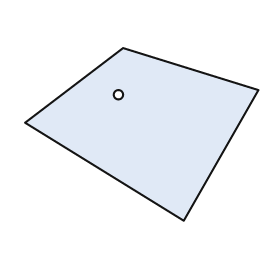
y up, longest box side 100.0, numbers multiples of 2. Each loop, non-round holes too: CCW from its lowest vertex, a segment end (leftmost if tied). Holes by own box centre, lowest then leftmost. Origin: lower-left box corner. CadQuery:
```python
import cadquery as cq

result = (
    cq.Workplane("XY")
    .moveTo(68.0, 0.0)
    .lineTo(100.0, 56.0)
    .lineTo(42.0, 74.0)
    .lineTo(0.0, 42.0)
    .close()
    .moveTo(40.0, 54.0)
    .circle(2.0)
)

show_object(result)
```